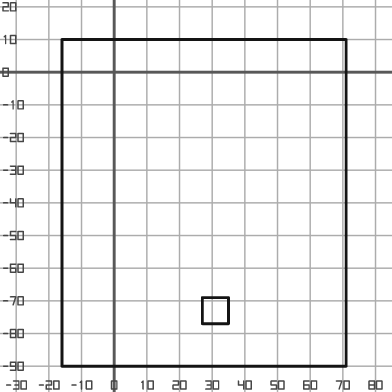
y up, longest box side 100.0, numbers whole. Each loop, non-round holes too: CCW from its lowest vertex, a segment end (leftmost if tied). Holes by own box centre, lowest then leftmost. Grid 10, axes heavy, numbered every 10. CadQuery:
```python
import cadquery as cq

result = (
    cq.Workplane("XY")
    .moveTo(-16.0, -90.0)
    .lineTo(71.0, -90.0)
    .lineTo(71.0, 10.0)
    .lineTo(-16.0, 10.0)
    .close()
    .moveTo(27.0, -77.0)
    .lineTo(35.0, -77.0)
    .lineTo(35.0, -69.0)
    .lineTo(27.0, -69.0)
    .close()
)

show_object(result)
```